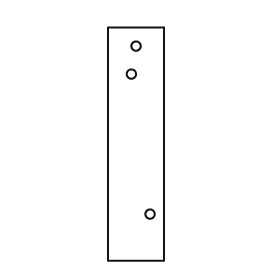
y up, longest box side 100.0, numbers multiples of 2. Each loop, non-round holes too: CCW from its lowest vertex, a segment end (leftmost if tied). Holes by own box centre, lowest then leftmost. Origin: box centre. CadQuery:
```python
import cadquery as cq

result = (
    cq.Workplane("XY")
    .moveTo(-12.0, -50.0)
    .lineTo(12.0, -50.0)
    .lineTo(12.0, 50.0)
    .lineTo(-12.0, 50.0)
    .close()
    .moveTo(6.0, -30.0)
    .circle(2.0)
    .moveTo(-2.0, 30.0)
    .circle(2.0)
    .moveTo(0.0, 42.0)
    .circle(2.0)
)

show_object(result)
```